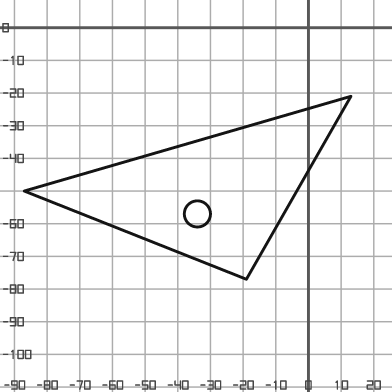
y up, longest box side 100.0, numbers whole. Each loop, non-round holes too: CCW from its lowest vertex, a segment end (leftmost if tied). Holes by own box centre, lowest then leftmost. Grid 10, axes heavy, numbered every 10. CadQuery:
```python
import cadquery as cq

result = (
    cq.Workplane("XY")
    .moveTo(-19.0, -77.0)
    .lineTo(13.0, -21.0)
    .lineTo(-87.0, -50.0)
    .close()
    .moveTo(-34.0, -57.0)
    .circle(4.0)
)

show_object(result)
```